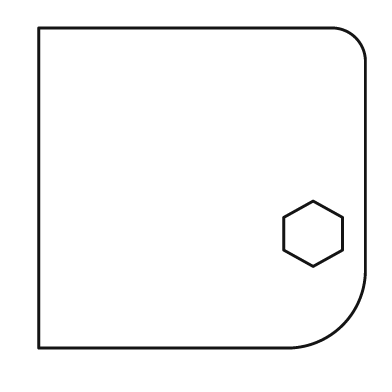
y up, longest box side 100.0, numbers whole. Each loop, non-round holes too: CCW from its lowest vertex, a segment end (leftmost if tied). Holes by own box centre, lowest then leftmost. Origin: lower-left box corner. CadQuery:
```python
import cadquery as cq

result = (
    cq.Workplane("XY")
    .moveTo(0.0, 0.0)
    .lineTo(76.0, 0.0)
    .threePointArc((93.0, 7.0), (100.0, 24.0))
    .lineTo(100.0, 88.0)
    .threePointArc((97.0, 95.0), (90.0, 98.0))
    .lineTo(0.0, 98.0)
    .close()
    .moveTo(84.0, 25.0)
    .lineTo(93.0, 30.0)
    .lineTo(93.0, 40.0)
    .lineTo(84.0, 45.0)
    .lineTo(75.0, 40.0)
    .lineTo(75.0, 30.0)
    .close()
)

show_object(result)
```